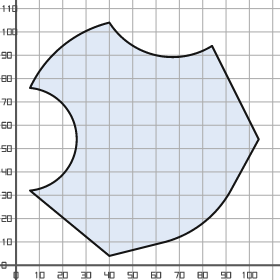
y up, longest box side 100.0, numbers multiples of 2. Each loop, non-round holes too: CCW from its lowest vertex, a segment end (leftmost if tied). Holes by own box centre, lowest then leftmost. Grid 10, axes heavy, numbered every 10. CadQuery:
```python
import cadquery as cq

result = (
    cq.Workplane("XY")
    .moveTo(40.0, 4.0)
    .lineTo(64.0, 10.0)
    .threePointArc((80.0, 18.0), (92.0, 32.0))
    .lineTo(104.0, 54.0)
    .lineTo(84.0, 94.0)
    .threePointArc((60.0, 90.0), (40.0, 104.0))
    .threePointArc((20.0, 94.0), (6.0, 76.0))
    .threePointArc((26.0, 54.0), (6.0, 32.0))
    .close()
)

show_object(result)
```